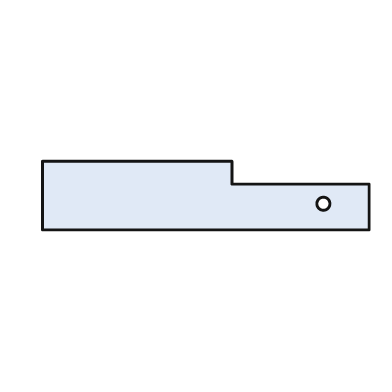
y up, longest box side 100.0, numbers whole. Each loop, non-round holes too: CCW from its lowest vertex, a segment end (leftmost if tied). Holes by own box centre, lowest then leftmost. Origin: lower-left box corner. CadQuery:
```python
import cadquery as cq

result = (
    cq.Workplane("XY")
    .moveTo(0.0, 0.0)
    .lineTo(100.0, 0.0)
    .lineTo(100.0, 14.0)
    .lineTo(58.0, 14.0)
    .lineTo(58.0, 21.0)
    .lineTo(0.0, 21.0)
    .close()
    .moveTo(86.0, 8.0)
    .circle(2.0)
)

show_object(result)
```